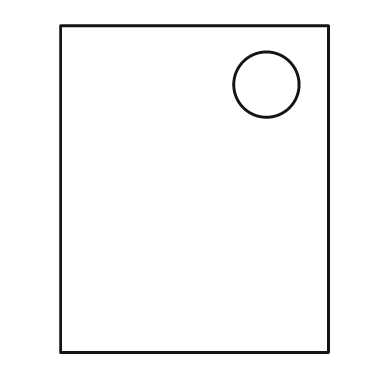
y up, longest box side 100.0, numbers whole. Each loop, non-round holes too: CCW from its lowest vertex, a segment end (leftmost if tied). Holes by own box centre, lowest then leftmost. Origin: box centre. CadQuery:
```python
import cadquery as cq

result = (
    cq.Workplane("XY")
    .moveTo(-41.0, -50.0)
    .lineTo(41.0, -50.0)
    .lineTo(41.0, 50.0)
    .lineTo(-41.0, 50.0)
    .close()
    .moveTo(22.0, 32.0)
    .circle(10.0)
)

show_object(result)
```